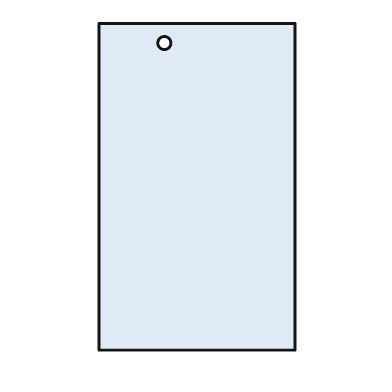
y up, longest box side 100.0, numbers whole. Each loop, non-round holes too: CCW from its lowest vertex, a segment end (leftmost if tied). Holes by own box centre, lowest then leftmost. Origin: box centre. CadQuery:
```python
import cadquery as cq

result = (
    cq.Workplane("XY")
    .moveTo(-30.0, -50.0)
    .lineTo(30.0, -50.0)
    .lineTo(30.0, 50.0)
    .lineTo(-30.0, 50.0)
    .close()
    .moveTo(-10.0, 44.0)
    .circle(2.0)
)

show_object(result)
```